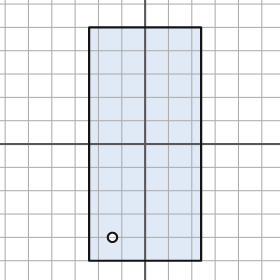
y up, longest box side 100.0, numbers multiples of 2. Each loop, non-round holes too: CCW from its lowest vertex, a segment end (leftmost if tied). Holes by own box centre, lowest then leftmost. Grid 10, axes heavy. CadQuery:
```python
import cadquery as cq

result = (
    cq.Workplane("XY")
    .moveTo(-24.0, -50.0)
    .lineTo(24.0, -50.0)
    .lineTo(24.0, 50.0)
    .lineTo(-24.0, 50.0)
    .close()
    .moveTo(-14.0, -40.0)
    .circle(2.0)
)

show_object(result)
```